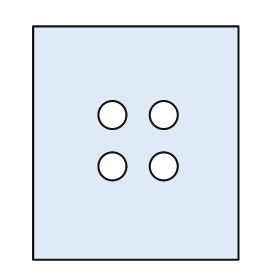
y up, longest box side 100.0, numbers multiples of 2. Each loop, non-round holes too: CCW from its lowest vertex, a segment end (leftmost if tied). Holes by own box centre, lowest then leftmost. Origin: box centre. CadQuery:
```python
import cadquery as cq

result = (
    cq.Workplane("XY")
    .moveTo(-44.0, -50.0)
    .lineTo(44.0, -50.0)
    .lineTo(44.0, 50.0)
    .lineTo(-44.0, 50.0)
    .close()
    .moveTo(-10.0, -10.0)
    .circle(6.0)
    .moveTo(12.0, -10.0)
    .circle(6.0)
    .moveTo(-10.0, 12.0)
    .circle(6.0)
    .moveTo(12.0, 12.0)
    .circle(6.0)
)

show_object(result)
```